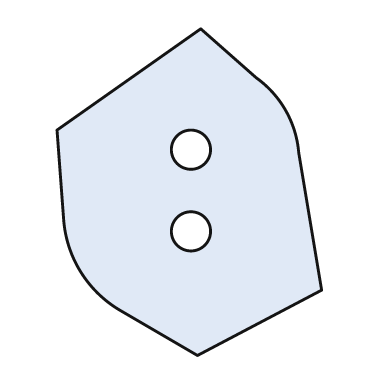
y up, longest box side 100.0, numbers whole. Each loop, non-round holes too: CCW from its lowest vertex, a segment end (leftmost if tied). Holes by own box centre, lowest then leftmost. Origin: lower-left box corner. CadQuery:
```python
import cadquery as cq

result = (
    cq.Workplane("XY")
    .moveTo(43.0, 0.0)
    .lineTo(81.0, 20.0)
    .lineTo(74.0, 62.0)
    .threePointArc((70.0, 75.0), (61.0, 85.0))
    .lineTo(44.0, 100.0)
    .lineTo(0.0, 69.0)
    .lineTo(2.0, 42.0)
    .threePointArc((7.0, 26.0), (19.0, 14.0))
    .close()
    .moveTo(41.0, 38.0)
    .circle(6.0)
    .moveTo(41.0, 63.0)
    .circle(6.0)
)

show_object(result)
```